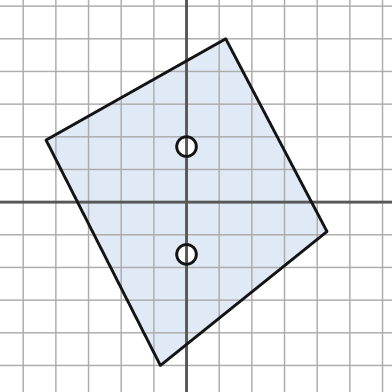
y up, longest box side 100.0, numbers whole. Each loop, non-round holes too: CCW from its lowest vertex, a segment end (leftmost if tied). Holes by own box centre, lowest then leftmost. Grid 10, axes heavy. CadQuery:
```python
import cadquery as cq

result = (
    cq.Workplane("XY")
    .moveTo(-8.0, -50.0)
    .lineTo(43.0, -9.0)
    .lineTo(12.0, 50.0)
    .lineTo(-43.0, 19.0)
    .close()
    .moveTo(0.0, -16.0)
    .circle(3.0)
    .moveTo(0.0, 17.0)
    .circle(3.0)
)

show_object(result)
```